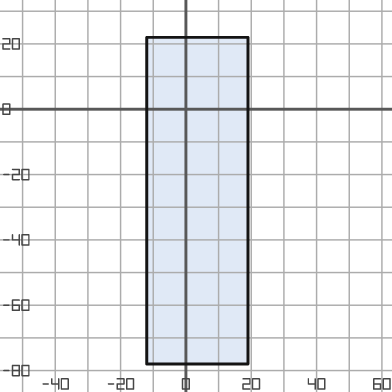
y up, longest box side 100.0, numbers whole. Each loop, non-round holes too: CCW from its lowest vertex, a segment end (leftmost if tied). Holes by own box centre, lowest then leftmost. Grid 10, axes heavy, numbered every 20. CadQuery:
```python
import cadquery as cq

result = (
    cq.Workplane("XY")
    .moveTo(-12.0, -78.0)
    .lineTo(19.0, -78.0)
    .lineTo(19.0, 22.0)
    .lineTo(-12.0, 22.0)
    .close()
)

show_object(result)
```